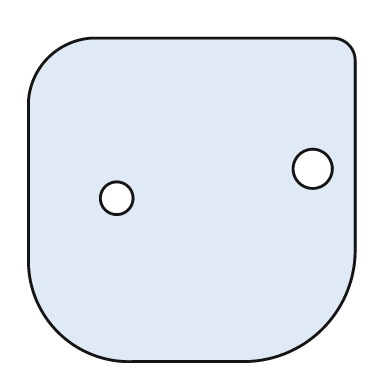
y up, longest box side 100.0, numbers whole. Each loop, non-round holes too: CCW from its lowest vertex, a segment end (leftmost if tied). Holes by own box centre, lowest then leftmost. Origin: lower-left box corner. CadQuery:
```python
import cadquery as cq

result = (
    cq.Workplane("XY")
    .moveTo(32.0, 0.0)
    .lineTo(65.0, 0.0)
    .threePointArc((90.0, 10.0), (100.0, 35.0))
    .lineTo(100.0, 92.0)
    .threePointArc((98.0, 97.0), (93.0, 99.0))
    .lineTo(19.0, 99.0)
    .threePointArc((6.0, 93.0), (0.0, 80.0))
    .lineTo(0.0, 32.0)
    .threePointArc((9.0, 9.0), (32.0, 0.0))
    .close()
    .moveTo(27.0, 50.0)
    .circle(5.0)
    .moveTo(87.0, 59.0)
    .circle(6.0)
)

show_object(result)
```